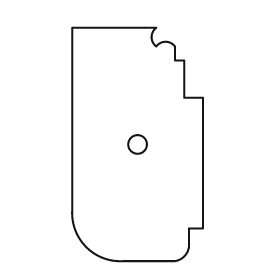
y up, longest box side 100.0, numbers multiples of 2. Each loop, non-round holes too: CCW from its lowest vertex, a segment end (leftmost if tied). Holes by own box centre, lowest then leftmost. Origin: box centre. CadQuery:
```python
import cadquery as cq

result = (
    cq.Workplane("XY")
    .moveTo(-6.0, -50.0)
    .lineTo(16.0, -50.0)
    .threePointArc((20.0, -48.0), (22.0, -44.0))
    .lineTo(22.0, -36.0)
    .lineTo(28.0, -36.0)
    .lineTo(28.0, 20.0)
    .lineTo(20.0, 20.0)
    .lineTo(20.0, 36.0)
    .lineTo(16.0, 36.0)
    .lineTo(16.0, 42.0)
    .threePointArc((12.0, 44.0), (8.0, 42.0))
    .threePointArc((6.0, 46.0), (8.0, 50.0))
    .lineTo(-28.0, 50.0)
    .lineTo(-28.0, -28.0)
    .threePointArc((-22.0, -44.0), (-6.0, -50.0))
    .close()
    .moveTo(0.0, 0.0)
    .circle(4.0)
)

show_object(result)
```